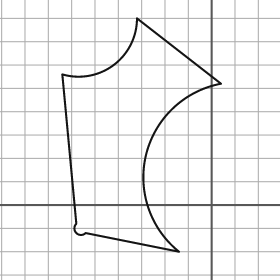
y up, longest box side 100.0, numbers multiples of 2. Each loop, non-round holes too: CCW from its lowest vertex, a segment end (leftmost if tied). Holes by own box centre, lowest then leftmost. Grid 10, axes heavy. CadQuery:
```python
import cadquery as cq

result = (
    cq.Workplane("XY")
    .moveTo(-14.0, -20.0)
    .threePointArc((-28.0, 22.0), (4.0, 52.0))
    .lineTo(-32.0, 80.0)
    .threePointArc((-42.0, 60.0), (-64.0, 56.0))
    .lineTo(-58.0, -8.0)
    .threePointArc((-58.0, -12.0), (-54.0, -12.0))
    .close()
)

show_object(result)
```